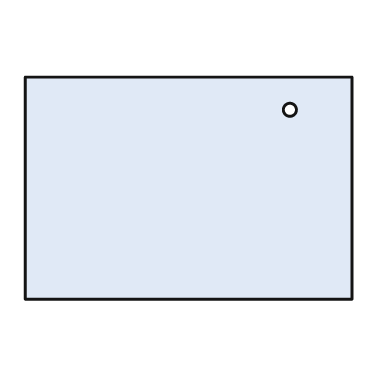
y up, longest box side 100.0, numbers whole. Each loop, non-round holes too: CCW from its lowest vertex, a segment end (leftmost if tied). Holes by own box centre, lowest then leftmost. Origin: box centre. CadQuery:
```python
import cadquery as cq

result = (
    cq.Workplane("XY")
    .moveTo(-50.0, -34.0)
    .lineTo(50.0, -34.0)
    .lineTo(50.0, 34.0)
    .lineTo(-50.0, 34.0)
    .close()
    .moveTo(31.0, 24.0)
    .circle(2.0)
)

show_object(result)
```